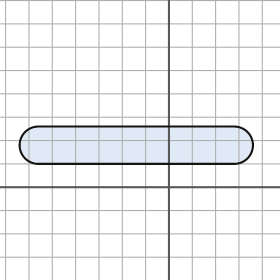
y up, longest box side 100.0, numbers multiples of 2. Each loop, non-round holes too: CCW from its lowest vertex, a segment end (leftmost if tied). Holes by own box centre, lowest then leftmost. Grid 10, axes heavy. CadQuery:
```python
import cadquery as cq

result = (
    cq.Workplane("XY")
    .moveTo(-56.0, 10.0)
    .lineTo(28.0, 10.0)
    .threePointArc((36.0, 18.0), (28.0, 26.0))
    .lineTo(-56.0, 26.0)
    .threePointArc((-64.0, 18.0), (-56.0, 10.0))
    .close()
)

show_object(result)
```